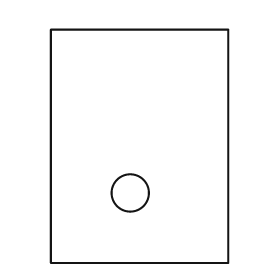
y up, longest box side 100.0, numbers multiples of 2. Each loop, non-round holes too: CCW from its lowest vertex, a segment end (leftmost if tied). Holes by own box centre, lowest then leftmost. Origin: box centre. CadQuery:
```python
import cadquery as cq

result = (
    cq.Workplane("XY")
    .moveTo(-38.0, -50.0)
    .lineTo(38.0, -50.0)
    .lineTo(38.0, 50.0)
    .lineTo(-38.0, 50.0)
    .close()
    .moveTo(-4.0, -20.0)
    .circle(8.0)
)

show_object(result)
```